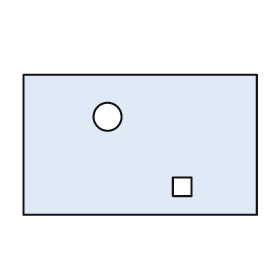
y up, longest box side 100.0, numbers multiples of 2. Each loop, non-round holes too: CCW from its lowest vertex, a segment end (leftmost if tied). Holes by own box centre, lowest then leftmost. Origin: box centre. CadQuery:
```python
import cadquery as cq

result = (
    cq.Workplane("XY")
    .moveTo(-50.0, -30.0)
    .lineTo(50.0, -30.0)
    .lineTo(50.0, 30.0)
    .lineTo(-50.0, 30.0)
    .close()
    .moveTo(14.0, -22.0)
    .lineTo(22.0, -22.0)
    .lineTo(22.0, -14.0)
    .lineTo(14.0, -14.0)
    .close()
    .moveTo(-14.0, 12.0)
    .circle(6.0)
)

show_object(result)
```